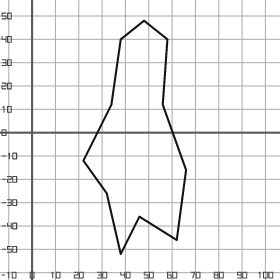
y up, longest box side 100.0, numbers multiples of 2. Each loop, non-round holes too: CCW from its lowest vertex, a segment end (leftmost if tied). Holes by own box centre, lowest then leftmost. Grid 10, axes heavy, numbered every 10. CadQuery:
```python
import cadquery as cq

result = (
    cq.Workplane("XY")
    .moveTo(38.0, -52.0)
    .lineTo(46.0, -36.0)
    .lineTo(62.0, -46.0)
    .lineTo(66.0, -16.0)
    .lineTo(56.0, 12.0)
    .lineTo(58.0, 40.0)
    .lineTo(48.0, 48.0)
    .lineTo(38.0, 40.0)
    .lineTo(34.0, 12.0)
    .lineTo(22.0, -12.0)
    .lineTo(32.0, -26.0)
    .close()
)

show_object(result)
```